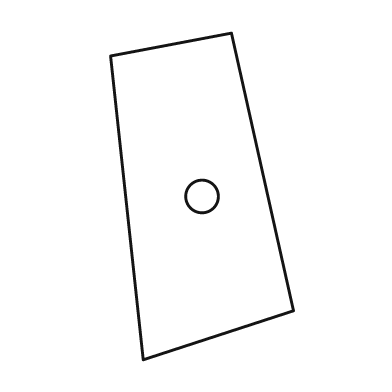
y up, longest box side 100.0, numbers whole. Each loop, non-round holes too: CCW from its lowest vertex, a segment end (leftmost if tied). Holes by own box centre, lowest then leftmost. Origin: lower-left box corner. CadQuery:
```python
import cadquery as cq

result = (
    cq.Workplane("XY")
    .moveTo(10.0, 0.0)
    .lineTo(56.0, 15.0)
    .lineTo(37.0, 100.0)
    .lineTo(0.0, 93.0)
    .close()
    .moveTo(28.0, 50.0)
    .circle(5.0)
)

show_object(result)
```